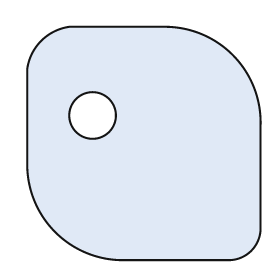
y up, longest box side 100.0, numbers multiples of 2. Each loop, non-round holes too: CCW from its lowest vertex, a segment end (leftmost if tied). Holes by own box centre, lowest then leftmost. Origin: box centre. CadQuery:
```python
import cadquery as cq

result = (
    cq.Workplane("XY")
    .moveTo(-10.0, -50.0)
    .lineTo(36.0, -50.0)
    .threePointArc((46.0, -46.0), (50.0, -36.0))
    .lineTo(50.0, 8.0)
    .threePointArc((38.0, 38.0), (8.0, 50.0))
    .lineTo(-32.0, 50.0)
    .threePointArc((-44.0, 44.0), (-50.0, 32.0))
    .lineTo(-50.0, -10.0)
    .threePointArc((-38.0, -38.0), (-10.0, -50.0))
    .close()
    .moveTo(-22.0, 12.0)
    .circle(10.0)
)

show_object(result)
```